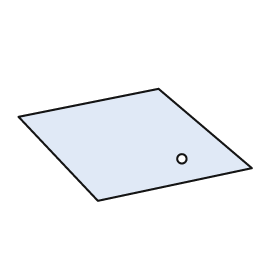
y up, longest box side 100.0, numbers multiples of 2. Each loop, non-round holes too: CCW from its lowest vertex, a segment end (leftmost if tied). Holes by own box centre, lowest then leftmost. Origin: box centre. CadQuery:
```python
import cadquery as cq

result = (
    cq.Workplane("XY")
    .moveTo(-16.0, -24.0)
    .lineTo(50.0, -10.0)
    .lineTo(10.0, 24.0)
    .lineTo(-50.0, 12.0)
    .close()
    .moveTo(20.0, -6.0)
    .circle(2.0)
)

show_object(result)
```